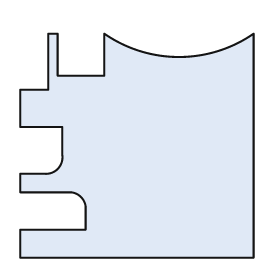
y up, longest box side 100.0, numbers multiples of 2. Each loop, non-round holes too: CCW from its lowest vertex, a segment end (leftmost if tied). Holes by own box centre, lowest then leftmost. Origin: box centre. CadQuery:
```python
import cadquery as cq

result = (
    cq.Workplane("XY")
    .moveTo(-50.0, -48.0)
    .lineTo(50.0, -48.0)
    .lineTo(50.0, 48.0)
    .threePointArc((18.0, 38.0), (-14.0, 48.0))
    .lineTo(-14.0, 30.0)
    .lineTo(-34.0, 30.0)
    .lineTo(-34.0, 48.0)
    .lineTo(-38.0, 48.0)
    .lineTo(-38.0, 24.0)
    .lineTo(-50.0, 24.0)
    .lineTo(-50.0, 8.0)
    .lineTo(-32.0, 8.0)
    .lineTo(-32.0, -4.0)
    .threePointArc((-34.0, -10.0), (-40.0, -12.0))
    .lineTo(-50.0, -12.0)
    .lineTo(-50.0, -20.0)
    .lineTo(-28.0, -20.0)
    .threePointArc((-24.0, -22.0), (-22.0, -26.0))
    .lineTo(-22.0, -36.0)
    .lineTo(-50.0, -36.0)
    .close()
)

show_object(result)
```